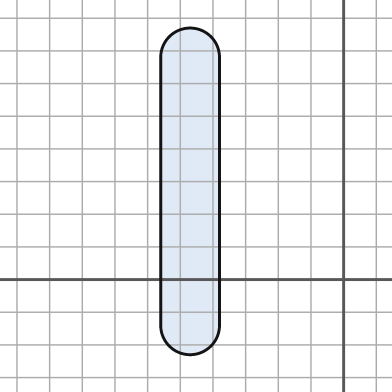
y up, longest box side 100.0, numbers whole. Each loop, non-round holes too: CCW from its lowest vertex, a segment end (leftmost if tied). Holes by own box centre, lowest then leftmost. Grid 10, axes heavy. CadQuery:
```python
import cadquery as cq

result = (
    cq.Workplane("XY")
    .moveTo(-56.0, -14.0)
    .threePointArc((-47.0, -23.0), (-38.0, -14.0))
    .lineTo(-38.0, 68.0)
    .threePointArc((-47.0, 77.0), (-56.0, 68.0))
    .close()
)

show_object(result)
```